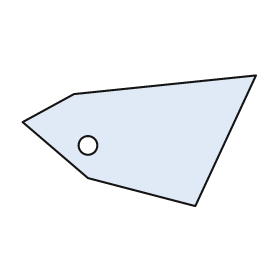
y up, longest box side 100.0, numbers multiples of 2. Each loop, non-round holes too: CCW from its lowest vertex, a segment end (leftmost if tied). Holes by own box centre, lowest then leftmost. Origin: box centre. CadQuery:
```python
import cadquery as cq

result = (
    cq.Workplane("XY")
    .moveTo(24.0, -28.0)
    .lineTo(50.0, 28.0)
    .lineTo(-28.0, 20.0)
    .lineTo(-50.0, 8.0)
    .lineTo(-22.0, -16.0)
    .close()
    .moveTo(-22.0, -2.0)
    .circle(4.0)
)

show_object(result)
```